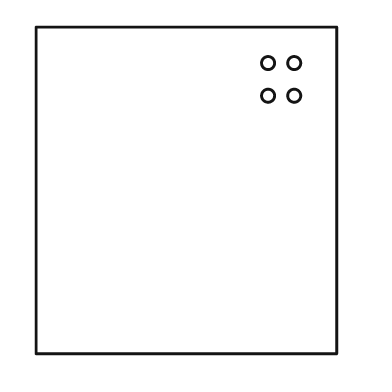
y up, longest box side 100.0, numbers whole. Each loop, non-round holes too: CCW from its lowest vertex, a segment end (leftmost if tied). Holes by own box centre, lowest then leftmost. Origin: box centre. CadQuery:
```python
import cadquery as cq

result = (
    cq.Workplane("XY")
    .moveTo(-46.0, -50.0)
    .lineTo(46.0, -50.0)
    .lineTo(46.0, 50.0)
    .lineTo(-46.0, 50.0)
    .close()
    .moveTo(25.0, 29.0)
    .circle(2.0)
    .moveTo(33.0, 29.0)
    .circle(2.0)
    .moveTo(25.0, 39.0)
    .circle(2.0)
    .moveTo(33.0, 39.0)
    .circle(2.0)
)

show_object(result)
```